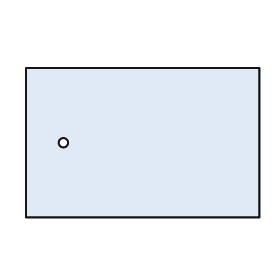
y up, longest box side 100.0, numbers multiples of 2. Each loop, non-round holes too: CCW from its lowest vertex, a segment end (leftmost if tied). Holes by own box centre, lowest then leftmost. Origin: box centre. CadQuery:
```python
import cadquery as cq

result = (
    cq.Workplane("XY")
    .moveTo(-50.0, -32.0)
    .lineTo(50.0, -32.0)
    .lineTo(50.0, 32.0)
    .lineTo(-50.0, 32.0)
    .close()
    .moveTo(-34.0, 0.0)
    .circle(2.0)
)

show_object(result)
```